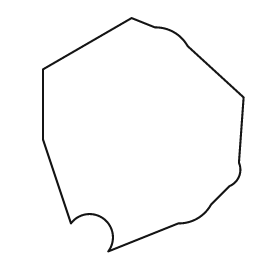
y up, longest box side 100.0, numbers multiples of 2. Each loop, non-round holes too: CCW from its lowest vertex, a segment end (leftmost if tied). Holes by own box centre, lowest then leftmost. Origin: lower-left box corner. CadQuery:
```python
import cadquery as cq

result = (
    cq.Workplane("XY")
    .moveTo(28.0, 0.0)
    .lineTo(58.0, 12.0)
    .threePointArc((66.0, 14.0), (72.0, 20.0))
    .lineTo(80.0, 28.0)
    .threePointArc((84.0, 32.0), (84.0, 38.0))
    .lineTo(86.0, 66.0)
    .lineTo(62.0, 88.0)
    .threePointArc((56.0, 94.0), (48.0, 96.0))
    .lineTo(38.0, 100.0)
    .lineTo(0.0, 78.0)
    .lineTo(0.0, 48.0)
    .lineTo(12.0, 12.0)
    .threePointArc((26.0, 14.0), (28.0, 0.0))
    .close()
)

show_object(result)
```